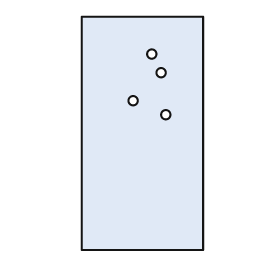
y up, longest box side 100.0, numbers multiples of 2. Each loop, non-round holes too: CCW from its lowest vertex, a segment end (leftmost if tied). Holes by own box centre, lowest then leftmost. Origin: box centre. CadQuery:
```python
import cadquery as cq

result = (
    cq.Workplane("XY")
    .moveTo(-26.0, -50.0)
    .lineTo(26.0, -50.0)
    .lineTo(26.0, 50.0)
    .lineTo(-26.0, 50.0)
    .close()
    .moveTo(10.0, 8.0)
    .circle(2.0)
    .moveTo(-4.0, 14.0)
    .circle(2.0)
    .moveTo(8.0, 26.0)
    .circle(2.0)
    .moveTo(4.0, 34.0)
    .circle(2.0)
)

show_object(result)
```